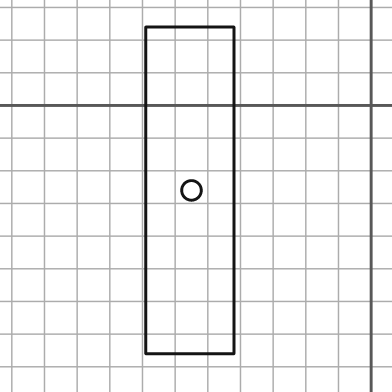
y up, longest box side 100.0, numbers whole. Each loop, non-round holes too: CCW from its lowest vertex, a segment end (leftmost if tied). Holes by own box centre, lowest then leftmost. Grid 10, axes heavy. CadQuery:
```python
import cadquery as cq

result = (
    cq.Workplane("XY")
    .moveTo(-69.0, -76.0)
    .lineTo(-42.0, -76.0)
    .lineTo(-42.0, 24.0)
    .lineTo(-69.0, 24.0)
    .close()
    .moveTo(-55.0, -26.0)
    .circle(3.0)
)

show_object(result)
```